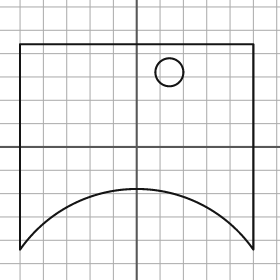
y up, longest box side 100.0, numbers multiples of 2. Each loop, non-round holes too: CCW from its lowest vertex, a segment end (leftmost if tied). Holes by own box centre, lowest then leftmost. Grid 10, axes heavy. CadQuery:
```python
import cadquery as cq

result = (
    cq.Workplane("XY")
    .moveTo(-50.0, -44.0)
    .threePointArc((0.0, -18.0), (50.0, -44.0))
    .lineTo(50.0, 44.0)
    .lineTo(-50.0, 44.0)
    .close()
    .moveTo(14.0, 32.0)
    .circle(6.0)
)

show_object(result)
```